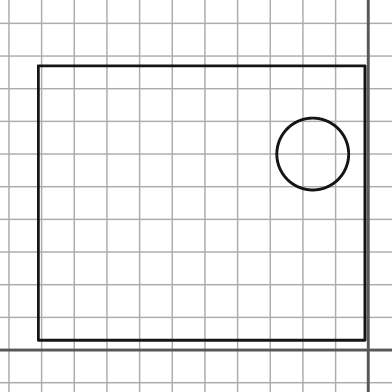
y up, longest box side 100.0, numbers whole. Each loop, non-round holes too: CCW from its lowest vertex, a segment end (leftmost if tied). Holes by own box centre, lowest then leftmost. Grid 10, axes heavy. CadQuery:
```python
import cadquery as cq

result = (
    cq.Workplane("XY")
    .moveTo(-101.0, 3.0)
    .lineTo(-1.0, 3.0)
    .lineTo(-1.0, 87.0)
    .lineTo(-101.0, 87.0)
    .close()
    .moveTo(-17.0, 60.0)
    .circle(11.0)
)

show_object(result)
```